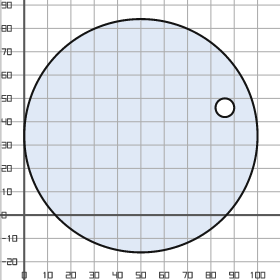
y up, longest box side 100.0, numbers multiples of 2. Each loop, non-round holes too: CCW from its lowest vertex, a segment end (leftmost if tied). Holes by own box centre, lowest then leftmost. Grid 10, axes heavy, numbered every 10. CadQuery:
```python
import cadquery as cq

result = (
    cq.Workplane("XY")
    .moveTo(50.0, 34.0)
    .circle(50.0)
    .moveTo(86.0, 46.0)
    .circle(4.0)
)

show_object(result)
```